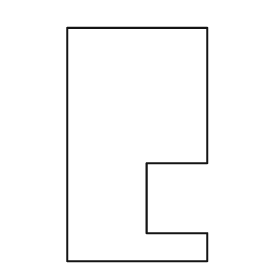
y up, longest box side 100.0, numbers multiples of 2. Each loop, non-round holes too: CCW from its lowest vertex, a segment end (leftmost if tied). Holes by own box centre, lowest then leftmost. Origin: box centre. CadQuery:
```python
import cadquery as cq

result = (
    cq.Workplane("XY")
    .moveTo(-30.0, -50.0)
    .lineTo(30.0, -50.0)
    .lineTo(30.0, -38.0)
    .lineTo(4.0, -38.0)
    .lineTo(4.0, -8.0)
    .lineTo(30.0, -8.0)
    .lineTo(30.0, 50.0)
    .lineTo(-30.0, 50.0)
    .close()
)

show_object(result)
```